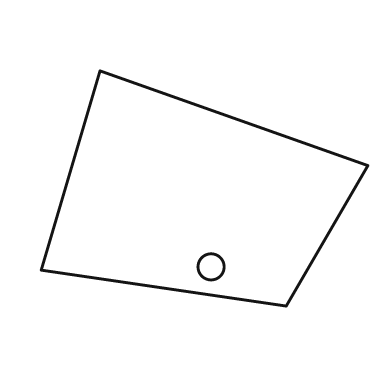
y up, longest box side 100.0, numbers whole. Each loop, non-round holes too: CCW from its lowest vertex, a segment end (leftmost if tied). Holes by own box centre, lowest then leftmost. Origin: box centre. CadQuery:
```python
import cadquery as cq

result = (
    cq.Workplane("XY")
    .moveTo(25.0, -36.0)
    .lineTo(50.0, 7.0)
    .lineTo(-32.0, 36.0)
    .lineTo(-50.0, -25.0)
    .close()
    .moveTo(2.0, -24.0)
    .circle(4.0)
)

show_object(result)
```